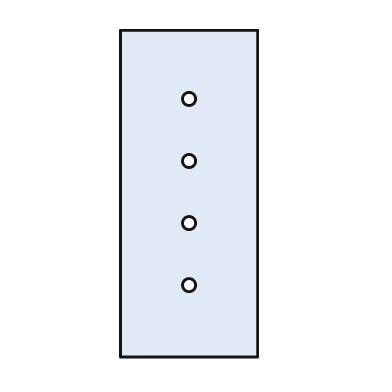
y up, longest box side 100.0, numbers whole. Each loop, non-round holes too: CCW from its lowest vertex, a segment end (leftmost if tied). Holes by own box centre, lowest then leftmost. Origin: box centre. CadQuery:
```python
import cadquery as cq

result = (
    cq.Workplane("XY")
    .moveTo(-21.0, -50.0)
    .lineTo(21.0, -50.0)
    .lineTo(21.0, 50.0)
    .lineTo(-21.0, 50.0)
    .close()
    .moveTo(0.0, -28.0)
    .circle(2.0)
    .moveTo(0.0, -9.0)
    .circle(2.0)
    .moveTo(0.0, 10.0)
    .circle(2.0)
    .moveTo(0.0, 29.0)
    .circle(2.0)
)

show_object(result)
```